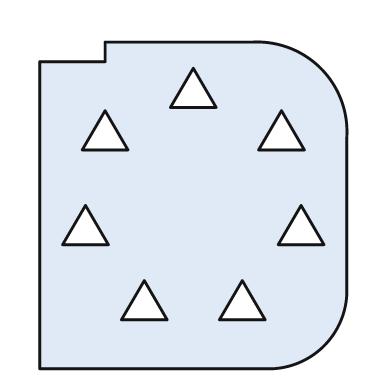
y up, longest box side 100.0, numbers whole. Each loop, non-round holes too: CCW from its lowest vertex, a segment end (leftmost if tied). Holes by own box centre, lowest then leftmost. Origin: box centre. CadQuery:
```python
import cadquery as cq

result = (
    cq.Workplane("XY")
    .moveTo(-47.0, -50.0)
    .lineTo(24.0, -50.0)
    .threePointArc((40.0, -43.0), (47.0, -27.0))
    .lineTo(47.0, 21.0)
    .threePointArc((39.0, 42.0), (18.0, 50.0))
    .lineTo(-27.0, 50.0)
    .lineTo(-27.0, 44.0)
    .lineTo(-47.0, 44.0)
    .close()
    .moveTo(-22.0, -35.0)
    .lineTo(-8.0, -35.0)
    .lineTo(-15.0, -23.0)
    .close()
    .moveTo(8.0, -35.0)
    .lineTo(22.0, -35.0)
    .lineTo(15.0, -23.0)
    .close()
    .moveTo(-40.0, -12.0)
    .lineTo(-26.0, -12.0)
    .lineTo(-33.0, 0.0)
    .close()
    .moveTo(26.0, -12.0)
    .lineTo(40.0, -12.0)
    .lineTo(33.0, 0.0)
    .close()
    .moveTo(-34.0, 17.0)
    .lineTo(-20.0, 17.0)
    .lineTo(-27.0, 29.0)
    .close()
    .moveTo(20.0, 17.0)
    .lineTo(34.0, 17.0)
    .lineTo(27.0, 29.0)
    .close()
    .moveTo(-7.0, 30.0)
    .lineTo(7.0, 30.0)
    .lineTo(0.0, 42.0)
    .close()
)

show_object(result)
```